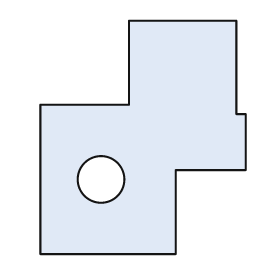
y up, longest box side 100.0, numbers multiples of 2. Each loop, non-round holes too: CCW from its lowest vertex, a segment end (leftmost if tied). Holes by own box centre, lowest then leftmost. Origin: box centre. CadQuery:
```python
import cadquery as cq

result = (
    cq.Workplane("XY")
    .moveTo(-44.0, -50.0)
    .lineTo(14.0, -50.0)
    .lineTo(14.0, -14.0)
    .lineTo(44.0, -14.0)
    .lineTo(44.0, 10.0)
    .lineTo(40.0, 10.0)
    .lineTo(40.0, 50.0)
    .lineTo(-6.0, 50.0)
    .lineTo(-6.0, 14.0)
    .lineTo(-44.0, 14.0)
    .close()
    .moveTo(-18.0, -18.0)
    .circle(10.0)
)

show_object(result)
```